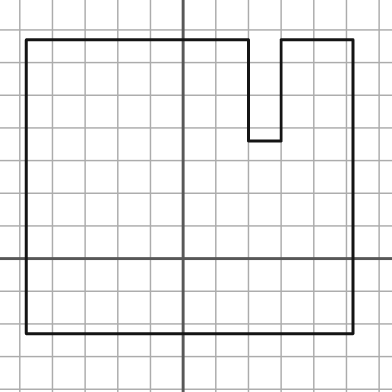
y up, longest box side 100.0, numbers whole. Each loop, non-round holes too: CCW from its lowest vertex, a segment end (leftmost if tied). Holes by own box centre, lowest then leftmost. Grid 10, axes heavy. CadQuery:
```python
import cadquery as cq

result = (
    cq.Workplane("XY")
    .moveTo(-48.0, -23.0)
    .lineTo(52.0, -23.0)
    .lineTo(52.0, 67.0)
    .lineTo(30.0, 67.0)
    .lineTo(30.0, 36.0)
    .lineTo(20.0, 36.0)
    .lineTo(20.0, 67.0)
    .lineTo(-48.0, 67.0)
    .close()
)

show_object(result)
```